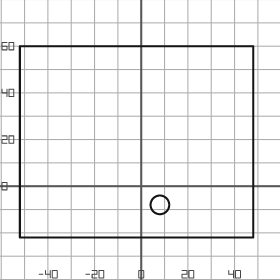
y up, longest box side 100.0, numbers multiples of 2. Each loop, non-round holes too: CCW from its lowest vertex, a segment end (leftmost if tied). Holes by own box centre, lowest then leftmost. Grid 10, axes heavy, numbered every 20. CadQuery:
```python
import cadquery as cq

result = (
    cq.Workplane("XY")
    .moveTo(-52.0, -22.0)
    .lineTo(48.0, -22.0)
    .lineTo(48.0, 60.0)
    .lineTo(-52.0, 60.0)
    .close()
    .moveTo(8.0, -8.0)
    .circle(4.0)
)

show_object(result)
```